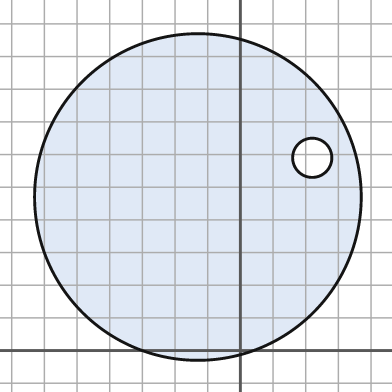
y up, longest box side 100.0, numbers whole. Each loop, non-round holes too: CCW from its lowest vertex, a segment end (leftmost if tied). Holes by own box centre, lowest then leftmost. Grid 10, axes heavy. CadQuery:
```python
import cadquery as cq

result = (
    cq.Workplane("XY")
    .moveTo(-13.0, 47.0)
    .circle(50.0)
    .moveTo(22.0, 59.0)
    .circle(6.0)
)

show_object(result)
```